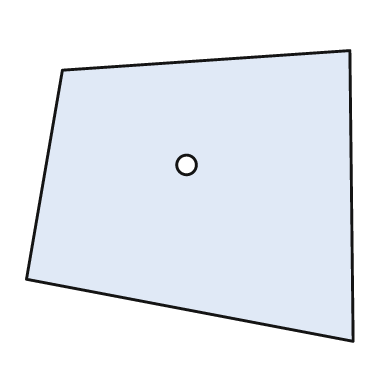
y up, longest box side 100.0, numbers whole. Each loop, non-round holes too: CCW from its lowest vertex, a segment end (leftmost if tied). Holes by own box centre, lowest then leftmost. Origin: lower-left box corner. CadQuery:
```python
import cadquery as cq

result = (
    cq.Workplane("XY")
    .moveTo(100.0, 0.0)
    .lineTo(99.0, 89.0)
    .lineTo(11.0, 83.0)
    .lineTo(0.0, 19.0)
    .close()
    .moveTo(49.0, 54.0)
    .circle(3.0)
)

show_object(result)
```